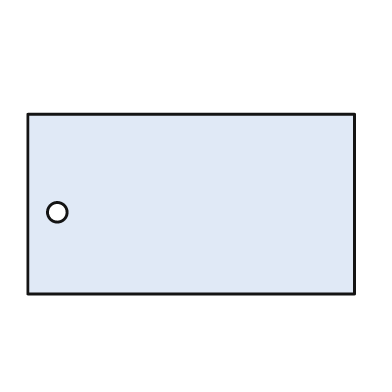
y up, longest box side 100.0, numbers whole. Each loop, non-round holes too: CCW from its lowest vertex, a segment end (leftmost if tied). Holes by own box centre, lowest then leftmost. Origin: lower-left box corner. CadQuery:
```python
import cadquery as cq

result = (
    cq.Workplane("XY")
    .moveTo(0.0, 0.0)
    .lineTo(100.0, 0.0)
    .lineTo(100.0, 55.0)
    .lineTo(0.0, 55.0)
    .close()
    .moveTo(9.0, 25.0)
    .circle(3.0)
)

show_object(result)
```